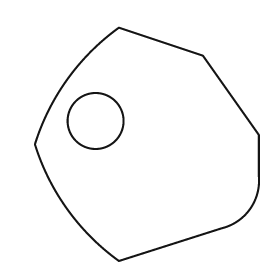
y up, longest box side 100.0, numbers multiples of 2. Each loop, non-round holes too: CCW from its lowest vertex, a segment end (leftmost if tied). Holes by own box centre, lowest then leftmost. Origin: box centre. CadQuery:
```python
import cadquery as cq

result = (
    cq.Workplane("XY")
    .moveTo(-12.0, -50.0)
    .lineTo(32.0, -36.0)
    .threePointArc((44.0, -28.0), (48.0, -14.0))
    .lineTo(48.0, 4.0)
    .lineTo(24.0, 38.0)
    .lineTo(-12.0, 50.0)
    .threePointArc((-34.0, 28.0), (-48.0, 0.0))
    .threePointArc((-34.0, -28.0), (-12.0, -50.0))
    .close()
    .moveTo(-22.0, 10.0)
    .circle(12.0)
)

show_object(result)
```